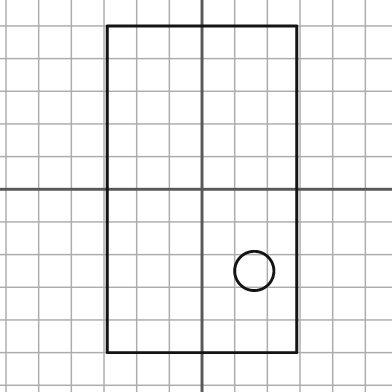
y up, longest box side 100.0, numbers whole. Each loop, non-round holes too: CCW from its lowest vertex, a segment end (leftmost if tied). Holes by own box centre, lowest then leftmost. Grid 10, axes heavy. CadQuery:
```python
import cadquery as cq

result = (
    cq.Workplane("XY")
    .moveTo(-29.0, -50.0)
    .lineTo(29.0, -50.0)
    .lineTo(29.0, 50.0)
    .lineTo(-29.0, 50.0)
    .close()
    .moveTo(16.0, -25.0)
    .circle(6.0)
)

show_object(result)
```